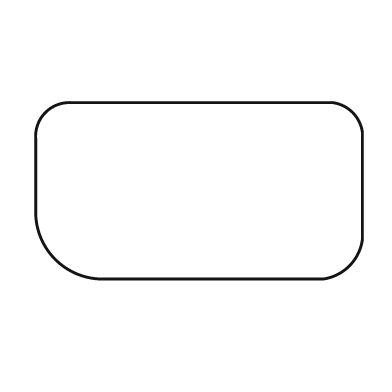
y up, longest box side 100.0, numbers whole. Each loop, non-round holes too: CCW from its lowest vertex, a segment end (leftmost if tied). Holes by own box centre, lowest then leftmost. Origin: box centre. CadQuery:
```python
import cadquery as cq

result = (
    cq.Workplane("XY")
    .moveTo(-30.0, -27.0)
    .lineTo(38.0, -27.0)
    .threePointArc((46.0, -23.0), (50.0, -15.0))
    .lineTo(50.0, 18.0)
    .threePointArc((47.0, 24.0), (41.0, 27.0))
    .lineTo(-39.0, 27.0)
    .threePointArc((-47.0, 24.0), (-50.0, 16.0))
    .lineTo(-50.0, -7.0)
    .threePointArc((-44.0, -21.0), (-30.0, -27.0))
    .close()
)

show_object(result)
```